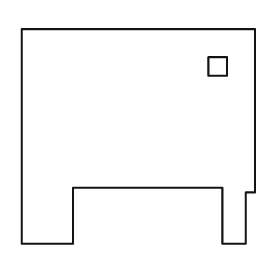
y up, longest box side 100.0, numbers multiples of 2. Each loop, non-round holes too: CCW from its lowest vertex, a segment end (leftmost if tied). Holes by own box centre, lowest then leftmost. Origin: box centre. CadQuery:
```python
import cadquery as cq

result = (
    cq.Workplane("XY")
    .moveTo(-50.0, -46.0)
    .lineTo(-28.0, -46.0)
    .lineTo(-28.0, -22.0)
    .lineTo(36.0, -22.0)
    .lineTo(36.0, -46.0)
    .lineTo(46.0, -46.0)
    .lineTo(46.0, -24.0)
    .lineTo(50.0, -24.0)
    .lineTo(50.0, 46.0)
    .lineTo(-50.0, 46.0)
    .close()
    .moveTo(30.0, 26.0)
    .lineTo(38.0, 26.0)
    .lineTo(38.0, 34.0)
    .lineTo(30.0, 34.0)
    .close()
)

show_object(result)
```